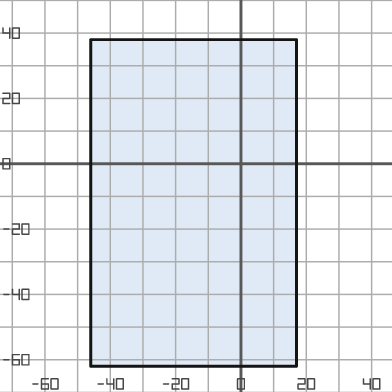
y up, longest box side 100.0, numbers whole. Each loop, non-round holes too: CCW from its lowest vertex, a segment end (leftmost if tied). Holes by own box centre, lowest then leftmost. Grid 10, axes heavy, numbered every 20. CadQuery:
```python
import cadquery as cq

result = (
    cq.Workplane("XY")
    .moveTo(-46.0, -62.0)
    .lineTo(17.0, -62.0)
    .lineTo(17.0, 38.0)
    .lineTo(-46.0, 38.0)
    .close()
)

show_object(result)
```